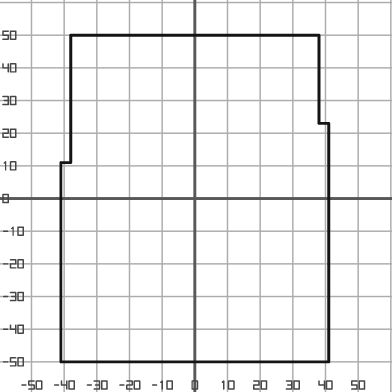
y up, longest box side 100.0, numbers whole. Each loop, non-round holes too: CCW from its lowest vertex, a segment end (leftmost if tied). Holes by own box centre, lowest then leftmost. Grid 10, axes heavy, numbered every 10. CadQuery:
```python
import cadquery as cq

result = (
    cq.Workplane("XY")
    .moveTo(-41.0, -50.0)
    .lineTo(41.0, -50.0)
    .lineTo(41.0, 23.0)
    .lineTo(38.0, 23.0)
    .lineTo(38.0, 50.0)
    .lineTo(-38.0, 50.0)
    .lineTo(-38.0, 11.0)
    .lineTo(-41.0, 11.0)
    .close()
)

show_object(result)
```